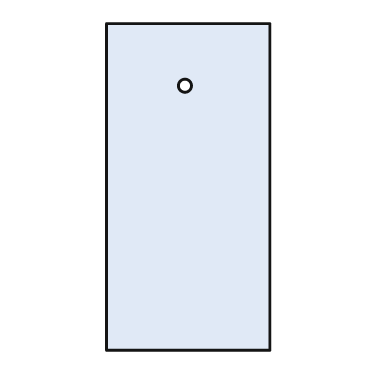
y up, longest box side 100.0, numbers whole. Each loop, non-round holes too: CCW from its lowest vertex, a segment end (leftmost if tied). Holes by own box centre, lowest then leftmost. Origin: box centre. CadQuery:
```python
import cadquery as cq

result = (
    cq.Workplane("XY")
    .moveTo(-25.0, -50.0)
    .lineTo(25.0, -50.0)
    .lineTo(25.0, 50.0)
    .lineTo(-25.0, 50.0)
    .close()
    .moveTo(-1.0, 31.0)
    .circle(2.0)
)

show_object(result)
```